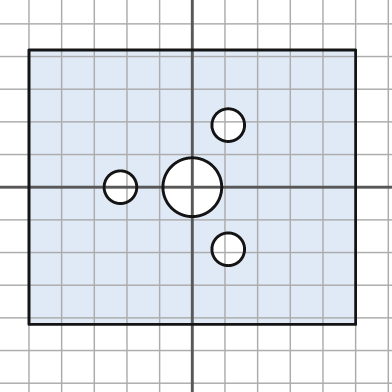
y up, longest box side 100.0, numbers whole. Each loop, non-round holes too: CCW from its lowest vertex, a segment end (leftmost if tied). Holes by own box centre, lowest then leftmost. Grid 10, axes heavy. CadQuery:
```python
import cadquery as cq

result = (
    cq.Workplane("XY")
    .moveTo(-50.0, -42.0)
    .lineTo(50.0, -42.0)
    .lineTo(50.0, 42.0)
    .lineTo(-50.0, 42.0)
    .close()
    .moveTo(11.0, -19.0)
    .circle(5.0)
    .moveTo(-22.0, 0.0)
    .circle(5.0)
    .moveTo(0.0, 0.0)
    .circle(9.0)
    .moveTo(11.0, 19.0)
    .circle(5.0)
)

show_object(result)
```